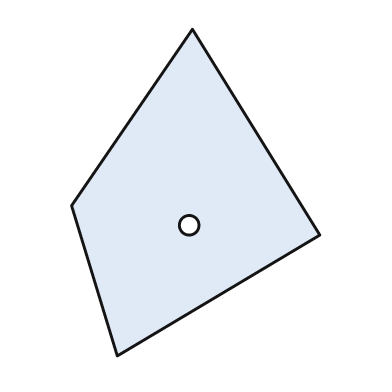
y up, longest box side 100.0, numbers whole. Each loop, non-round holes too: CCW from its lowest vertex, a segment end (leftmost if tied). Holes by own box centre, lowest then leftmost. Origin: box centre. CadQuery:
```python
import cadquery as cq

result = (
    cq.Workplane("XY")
    .moveTo(-24.0, -50.0)
    .lineTo(38.0, -13.0)
    .lineTo(-1.0, 50.0)
    .lineTo(-38.0, -4.0)
    .close()
    .moveTo(-2.0, -10.0)
    .circle(3.0)
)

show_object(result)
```